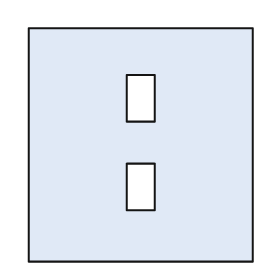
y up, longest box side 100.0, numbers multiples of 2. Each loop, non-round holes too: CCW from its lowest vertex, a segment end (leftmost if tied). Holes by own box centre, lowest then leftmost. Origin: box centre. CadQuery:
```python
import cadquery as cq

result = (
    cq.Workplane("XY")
    .moveTo(-48.0, -50.0)
    .lineTo(48.0, -50.0)
    .lineTo(48.0, 50.0)
    .lineTo(-48.0, 50.0)
    .close()
    .moveTo(-6.0, -28.0)
    .lineTo(6.0, -28.0)
    .lineTo(6.0, -8.0)
    .lineTo(-6.0, -8.0)
    .close()
    .moveTo(-6.0, 10.0)
    .lineTo(6.0, 10.0)
    .lineTo(6.0, 30.0)
    .lineTo(-6.0, 30.0)
    .close()
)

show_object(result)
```